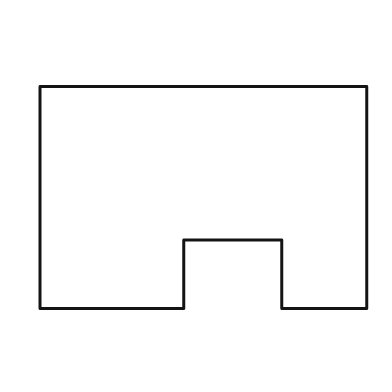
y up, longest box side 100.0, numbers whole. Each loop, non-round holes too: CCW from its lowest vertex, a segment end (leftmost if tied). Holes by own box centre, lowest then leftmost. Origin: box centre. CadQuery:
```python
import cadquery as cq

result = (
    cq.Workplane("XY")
    .moveTo(-50.0, -34.0)
    .lineTo(-6.0, -34.0)
    .lineTo(-6.0, -13.0)
    .lineTo(24.0, -13.0)
    .lineTo(24.0, -34.0)
    .lineTo(50.0, -34.0)
    .lineTo(50.0, 34.0)
    .lineTo(-50.0, 34.0)
    .close()
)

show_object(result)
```